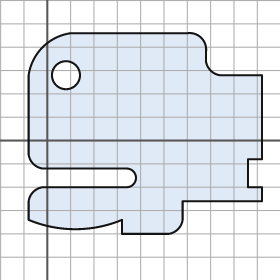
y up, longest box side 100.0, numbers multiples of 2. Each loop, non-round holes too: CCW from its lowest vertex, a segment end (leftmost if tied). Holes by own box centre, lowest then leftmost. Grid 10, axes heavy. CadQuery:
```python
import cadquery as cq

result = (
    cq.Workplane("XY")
    .moveTo(32.0, -40.0)
    .lineTo(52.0, -40.0)
    .threePointArc((56.0, -38.0), (58.0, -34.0))
    .lineTo(58.0, -26.0)
    .lineTo(92.0, -26.0)
    .lineTo(92.0, -20.0)
    .lineTo(86.0, -20.0)
    .lineTo(86.0, -8.0)
    .lineTo(92.0, -8.0)
    .lineTo(92.0, 28.0)
    .lineTo(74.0, 28.0)
    .threePointArc((70.0, 30.0), (68.0, 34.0))
    .lineTo(68.0, 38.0)
    .threePointArc((66.0, 44.0), (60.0, 46.0))
    .lineTo(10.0, 46.0)
    .threePointArc((-2.0, 40.0), (-8.0, 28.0))
    .lineTo(-8.0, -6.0)
    .threePointArc((-6.0, -10.0), (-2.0, -12.0))
    .lineTo(34.0, -12.0)
    .threePointArc((38.0, -16.0), (34.0, -20.0))
    .lineTo(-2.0, -20.0)
    .threePointArc((-6.0, -22.0), (-8.0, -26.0))
    .lineTo(-8.0, -34.0)
    .threePointArc((12.0, -38.0), (32.0, -34.0))
    .close()
    .moveTo(8.0, 28.0)
    .circle(6.0)
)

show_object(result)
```